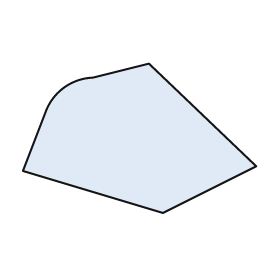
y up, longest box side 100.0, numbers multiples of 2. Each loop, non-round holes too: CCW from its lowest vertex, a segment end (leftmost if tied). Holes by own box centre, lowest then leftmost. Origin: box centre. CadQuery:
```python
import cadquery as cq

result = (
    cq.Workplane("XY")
    .moveTo(10.0, -32.0)
    .lineTo(50.0, -12.0)
    .lineTo(4.0, 32.0)
    .lineTo(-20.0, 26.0)
    .threePointArc((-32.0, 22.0), (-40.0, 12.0))
    .lineTo(-50.0, -14.0)
    .close()
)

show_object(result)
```